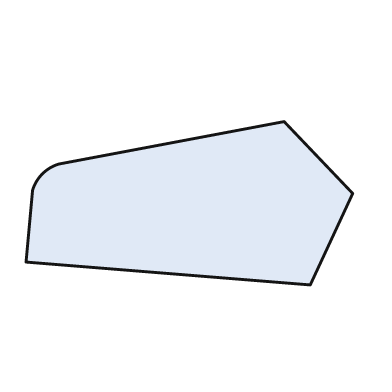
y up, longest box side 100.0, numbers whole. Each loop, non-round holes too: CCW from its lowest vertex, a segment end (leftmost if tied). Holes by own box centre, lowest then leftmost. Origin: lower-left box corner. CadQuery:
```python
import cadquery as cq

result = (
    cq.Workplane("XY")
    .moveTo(87.0, 0.0)
    .lineTo(100.0, 28.0)
    .lineTo(79.0, 50.0)
    .lineTo(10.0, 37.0)
    .threePointArc((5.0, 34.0), (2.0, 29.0))
    .lineTo(0.0, 7.0)
    .close()
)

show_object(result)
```